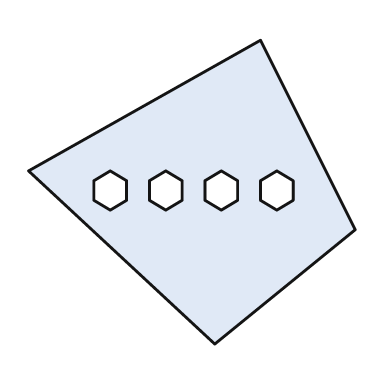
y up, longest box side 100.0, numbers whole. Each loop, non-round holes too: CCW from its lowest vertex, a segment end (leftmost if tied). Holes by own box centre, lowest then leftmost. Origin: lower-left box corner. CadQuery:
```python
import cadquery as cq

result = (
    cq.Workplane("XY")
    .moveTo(57.0, 0.0)
    .lineTo(100.0, 35.0)
    .lineTo(71.0, 93.0)
    .lineTo(0.0, 53.0)
    .close()
    .moveTo(25.0, 41.0)
    .lineTo(30.0, 44.0)
    .lineTo(30.0, 50.0)
    .lineTo(25.0, 53.0)
    .lineTo(20.0, 50.0)
    .lineTo(20.0, 44.0)
    .close()
    .moveTo(42.0, 41.0)
    .lineTo(47.0, 44.0)
    .lineTo(47.0, 50.0)
    .lineTo(42.0, 53.0)
    .lineTo(37.0, 50.0)
    .lineTo(37.0, 44.0)
    .close()
    .moveTo(59.0, 41.0)
    .lineTo(64.0, 44.0)
    .lineTo(64.0, 50.0)
    .lineTo(59.0, 53.0)
    .lineTo(54.0, 50.0)
    .lineTo(54.0, 44.0)
    .close()
    .moveTo(76.0, 41.0)
    .lineTo(81.0, 44.0)
    .lineTo(81.0, 50.0)
    .lineTo(76.0, 53.0)
    .lineTo(71.0, 50.0)
    .lineTo(71.0, 44.0)
    .close()
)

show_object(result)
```